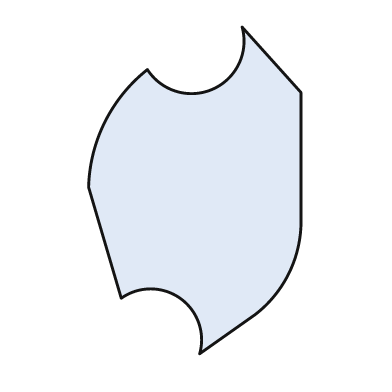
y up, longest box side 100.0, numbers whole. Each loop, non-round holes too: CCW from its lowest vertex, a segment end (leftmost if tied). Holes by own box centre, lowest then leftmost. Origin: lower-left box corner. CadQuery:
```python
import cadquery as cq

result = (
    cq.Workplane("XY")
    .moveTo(34.0, 0.0)
    .lineTo(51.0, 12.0)
    .threePointArc((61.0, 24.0), (65.0, 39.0))
    .lineTo(65.0, 80.0)
    .lineTo(47.0, 100.0)
    .threePointArc((38.0, 81.0), (18.0, 87.0))
    .threePointArc((5.0, 71.0), (0.0, 51.0))
    .lineTo(10.0, 17.0)
    .threePointArc((28.0, 17.0), (34.0, 0.0))
    .close()
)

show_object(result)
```